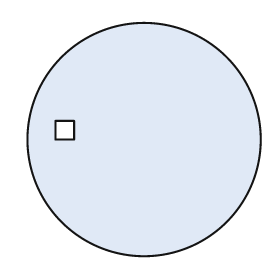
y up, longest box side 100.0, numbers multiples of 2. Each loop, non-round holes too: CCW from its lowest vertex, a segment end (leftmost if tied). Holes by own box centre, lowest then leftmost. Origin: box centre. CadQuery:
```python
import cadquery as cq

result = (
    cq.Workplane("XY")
    .moveTo(0.0, 0.0)
    .circle(50.0)
    .moveTo(-38.0, 0.0)
    .lineTo(-30.0, 0.0)
    .lineTo(-30.0, 8.0)
    .lineTo(-38.0, 8.0)
    .close()
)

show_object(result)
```